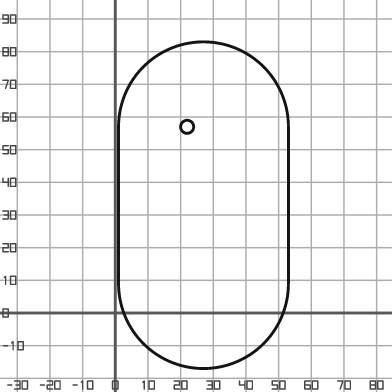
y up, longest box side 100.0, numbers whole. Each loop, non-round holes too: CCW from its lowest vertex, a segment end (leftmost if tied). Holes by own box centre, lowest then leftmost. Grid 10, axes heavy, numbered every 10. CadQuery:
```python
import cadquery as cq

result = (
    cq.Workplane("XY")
    .moveTo(1.0, 9.0)
    .threePointArc((27.0, -17.0), (53.0, 9.0))
    .lineTo(53.0, 57.0)
    .threePointArc((27.0, 83.0), (1.0, 57.0))
    .close()
    .moveTo(22.0, 57.0)
    .circle(2.0)
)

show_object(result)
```